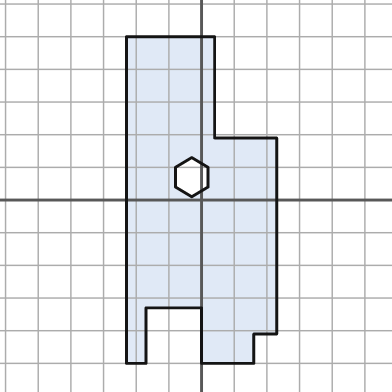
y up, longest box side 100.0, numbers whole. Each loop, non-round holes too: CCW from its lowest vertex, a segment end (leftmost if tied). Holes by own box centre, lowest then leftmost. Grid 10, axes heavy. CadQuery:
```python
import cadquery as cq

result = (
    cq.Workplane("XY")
    .moveTo(-23.0, -50.0)
    .lineTo(-17.0, -50.0)
    .lineTo(-17.0, -33.0)
    .lineTo(0.0, -33.0)
    .lineTo(0.0, -50.0)
    .lineTo(16.0, -50.0)
    .lineTo(16.0, -41.0)
    .lineTo(23.0, -41.0)
    .lineTo(23.0, 19.0)
    .lineTo(4.0, 19.0)
    .lineTo(4.0, 50.0)
    .lineTo(-23.0, 50.0)
    .close()
    .moveTo(-3.0, 1.0)
    .lineTo(2.0, 4.0)
    .lineTo(2.0, 10.0)
    .lineTo(-3.0, 13.0)
    .lineTo(-8.0, 10.0)
    .lineTo(-8.0, 4.0)
    .close()
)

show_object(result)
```